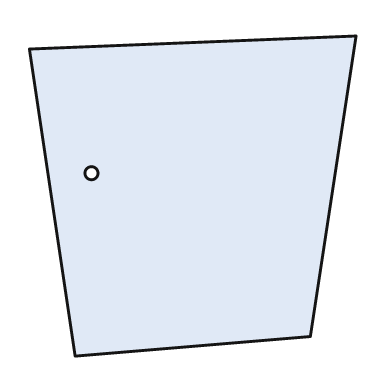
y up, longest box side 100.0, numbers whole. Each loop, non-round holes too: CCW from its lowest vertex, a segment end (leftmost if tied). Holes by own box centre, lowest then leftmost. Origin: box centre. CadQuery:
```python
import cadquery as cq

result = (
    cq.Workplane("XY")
    .moveTo(-36.0, -49.0)
    .lineTo(36.0, -43.0)
    .lineTo(50.0, 49.0)
    .lineTo(-50.0, 45.0)
    .close()
    .moveTo(-31.0, 7.0)
    .circle(2.0)
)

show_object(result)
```